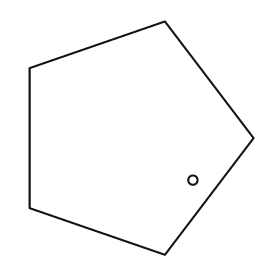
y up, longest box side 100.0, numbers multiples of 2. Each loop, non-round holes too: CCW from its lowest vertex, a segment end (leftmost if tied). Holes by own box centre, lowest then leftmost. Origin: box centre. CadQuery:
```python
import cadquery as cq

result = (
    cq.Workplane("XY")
    .moveTo(10.0, -50.0)
    .lineTo(48.0, 0.0)
    .lineTo(10.0, 50.0)
    .lineTo(-48.0, 30.0)
    .lineTo(-48.0, -30.0)
    .close()
    .moveTo(22.0, -18.0)
    .circle(2.0)
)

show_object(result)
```